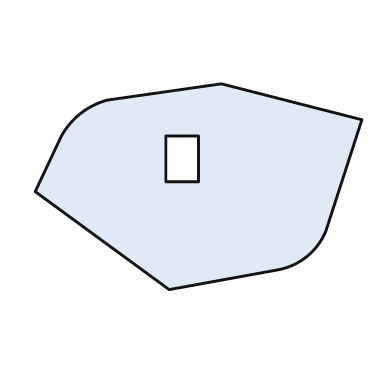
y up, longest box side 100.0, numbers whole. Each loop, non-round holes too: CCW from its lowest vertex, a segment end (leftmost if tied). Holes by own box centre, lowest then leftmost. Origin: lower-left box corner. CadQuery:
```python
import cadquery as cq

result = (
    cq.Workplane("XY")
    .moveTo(41.0, 0.0)
    .lineTo(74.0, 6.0)
    .threePointArc((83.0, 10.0), (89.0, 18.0))
    .lineTo(100.0, 52.0)
    .lineTo(57.0, 63.0)
    .lineTo(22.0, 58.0)
    .threePointArc((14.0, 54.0), (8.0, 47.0))
    .lineTo(0.0, 30.0)
    .close()
    .moveTo(40.0, 33.0)
    .lineTo(50.0, 33.0)
    .lineTo(50.0, 47.0)
    .lineTo(40.0, 47.0)
    .close()
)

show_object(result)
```